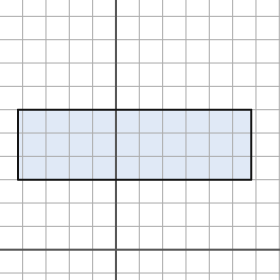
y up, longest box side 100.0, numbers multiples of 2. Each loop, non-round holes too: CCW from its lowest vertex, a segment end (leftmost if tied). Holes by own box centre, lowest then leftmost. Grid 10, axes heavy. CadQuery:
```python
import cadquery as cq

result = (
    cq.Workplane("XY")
    .moveTo(-42.0, 30.0)
    .lineTo(58.0, 30.0)
    .lineTo(58.0, 60.0)
    .lineTo(-42.0, 60.0)
    .close()
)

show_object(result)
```